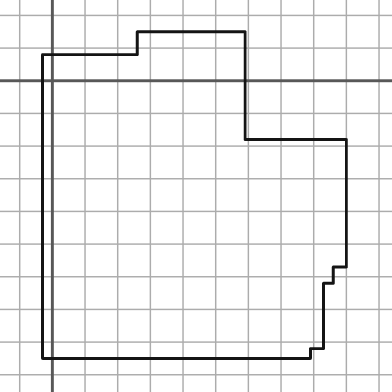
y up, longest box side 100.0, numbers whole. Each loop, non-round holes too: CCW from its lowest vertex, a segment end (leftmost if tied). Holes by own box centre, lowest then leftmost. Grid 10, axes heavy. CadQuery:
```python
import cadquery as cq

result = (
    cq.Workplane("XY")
    .moveTo(-3.0, -85.0)
    .lineTo(79.0, -85.0)
    .lineTo(79.0, -82.0)
    .lineTo(83.0, -82.0)
    .lineTo(83.0, -62.0)
    .lineTo(86.0, -62.0)
    .lineTo(86.0, -57.0)
    .lineTo(90.0, -57.0)
    .lineTo(90.0, -18.0)
    .lineTo(59.0, -18.0)
    .lineTo(59.0, 15.0)
    .lineTo(26.0, 15.0)
    .lineTo(26.0, 8.0)
    .lineTo(-3.0, 8.0)
    .close()
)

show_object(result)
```